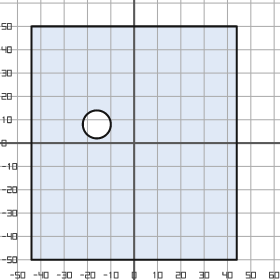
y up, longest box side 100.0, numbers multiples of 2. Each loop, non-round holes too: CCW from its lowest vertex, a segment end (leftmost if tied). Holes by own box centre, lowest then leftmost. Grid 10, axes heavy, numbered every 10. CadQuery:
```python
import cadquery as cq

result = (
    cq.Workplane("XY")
    .moveTo(-44.0, -50.0)
    .lineTo(44.0, -50.0)
    .lineTo(44.0, 50.0)
    .lineTo(-44.0, 50.0)
    .close()
    .moveTo(-16.0, 8.0)
    .circle(6.0)
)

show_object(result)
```